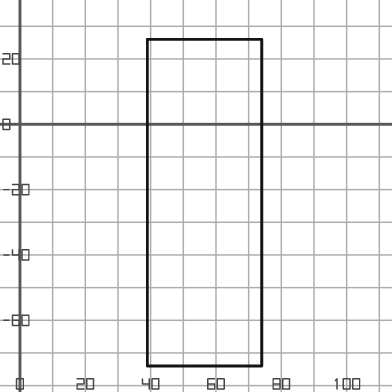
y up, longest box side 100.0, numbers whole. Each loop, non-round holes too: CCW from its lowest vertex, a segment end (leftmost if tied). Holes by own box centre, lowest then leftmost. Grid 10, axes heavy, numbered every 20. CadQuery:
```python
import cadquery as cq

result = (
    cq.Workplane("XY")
    .moveTo(39.0, -74.0)
    .lineTo(74.0, -74.0)
    .lineTo(74.0, 26.0)
    .lineTo(39.0, 26.0)
    .close()
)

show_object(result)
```